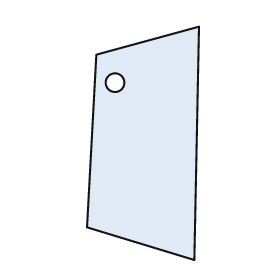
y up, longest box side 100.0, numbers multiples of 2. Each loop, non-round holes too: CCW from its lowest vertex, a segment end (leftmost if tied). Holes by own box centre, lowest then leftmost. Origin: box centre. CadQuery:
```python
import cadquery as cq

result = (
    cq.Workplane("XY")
    .moveTo(22.0, -50.0)
    .lineTo(24.0, 50.0)
    .lineTo(-20.0, 38.0)
    .lineTo(-24.0, -36.0)
    .close()
    .moveTo(-12.0, 26.0)
    .circle(4.0)
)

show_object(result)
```